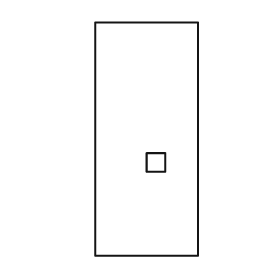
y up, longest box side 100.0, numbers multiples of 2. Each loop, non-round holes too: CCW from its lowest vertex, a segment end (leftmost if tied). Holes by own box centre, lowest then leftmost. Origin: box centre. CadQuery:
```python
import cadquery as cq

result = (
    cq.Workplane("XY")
    .moveTo(-22.0, -50.0)
    .lineTo(22.0, -50.0)
    .lineTo(22.0, 50.0)
    .lineTo(-22.0, 50.0)
    .close()
    .moveTo(0.0, -14.0)
    .lineTo(8.0, -14.0)
    .lineTo(8.0, -6.0)
    .lineTo(0.0, -6.0)
    .close()
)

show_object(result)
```